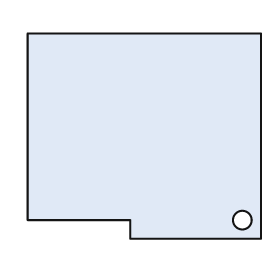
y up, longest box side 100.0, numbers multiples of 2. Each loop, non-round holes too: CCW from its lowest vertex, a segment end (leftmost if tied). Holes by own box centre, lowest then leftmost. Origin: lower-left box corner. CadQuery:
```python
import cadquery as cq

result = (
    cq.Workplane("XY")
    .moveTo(44.0, 0.0)
    .lineTo(100.0, 0.0)
    .lineTo(100.0, 88.0)
    .lineTo(0.0, 88.0)
    .lineTo(0.0, 8.0)
    .lineTo(44.0, 8.0)
    .close()
    .moveTo(92.0, 8.0)
    .circle(4.0)
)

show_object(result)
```